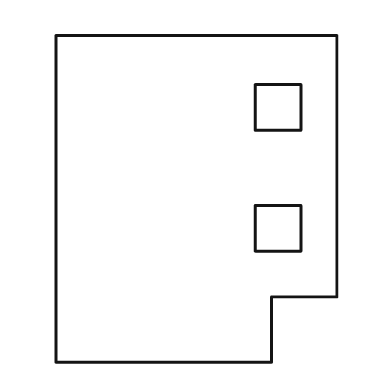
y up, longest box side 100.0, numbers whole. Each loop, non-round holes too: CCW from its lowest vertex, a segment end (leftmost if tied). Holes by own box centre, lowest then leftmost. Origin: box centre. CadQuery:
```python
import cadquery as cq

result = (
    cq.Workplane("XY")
    .moveTo(-43.0, -50.0)
    .lineTo(23.0, -50.0)
    .lineTo(23.0, -30.0)
    .lineTo(43.0, -30.0)
    .lineTo(43.0, 50.0)
    .lineTo(-43.0, 50.0)
    .close()
    .moveTo(18.0, -16.0)
    .lineTo(32.0, -16.0)
    .lineTo(32.0, -2.0)
    .lineTo(18.0, -2.0)
    .close()
    .moveTo(18.0, 21.0)
    .lineTo(32.0, 21.0)
    .lineTo(32.0, 35.0)
    .lineTo(18.0, 35.0)
    .close()
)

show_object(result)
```